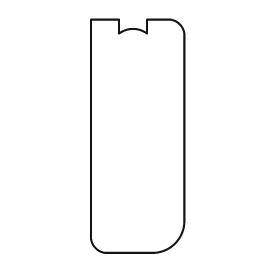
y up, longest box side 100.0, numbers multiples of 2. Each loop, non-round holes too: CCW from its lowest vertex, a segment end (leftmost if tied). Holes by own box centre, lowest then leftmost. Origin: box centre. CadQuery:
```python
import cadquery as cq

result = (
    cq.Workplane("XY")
    .moveTo(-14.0, -50.0)
    .lineTo(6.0, -50.0)
    .threePointArc((16.0, -46.0), (20.0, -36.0))
    .lineTo(20.0, 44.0)
    .threePointArc((18.0, 48.0), (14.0, 50.0))
    .lineTo(4.0, 50.0)
    .lineTo(4.0, 44.0)
    .threePointArc((-2.0, 46.0), (-8.0, 44.0))
    .lineTo(-8.0, 50.0)
    .lineTo(-20.0, 50.0)
    .lineTo(-20.0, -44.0)
    .threePointArc((-18.0, -48.0), (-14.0, -50.0))
    .close()
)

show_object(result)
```